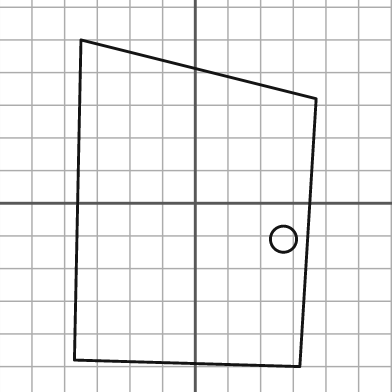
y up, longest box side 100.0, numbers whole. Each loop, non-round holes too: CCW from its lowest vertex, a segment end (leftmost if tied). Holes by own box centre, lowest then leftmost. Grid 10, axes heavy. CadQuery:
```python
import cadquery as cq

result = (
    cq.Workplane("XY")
    .moveTo(32.0, -50.0)
    .lineTo(37.0, 32.0)
    .lineTo(-35.0, 50.0)
    .lineTo(-37.0, -48.0)
    .close()
    .moveTo(27.0, -11.0)
    .circle(4.0)
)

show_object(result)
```